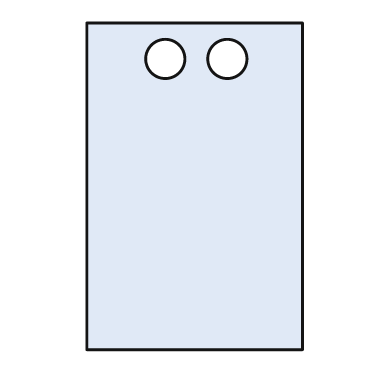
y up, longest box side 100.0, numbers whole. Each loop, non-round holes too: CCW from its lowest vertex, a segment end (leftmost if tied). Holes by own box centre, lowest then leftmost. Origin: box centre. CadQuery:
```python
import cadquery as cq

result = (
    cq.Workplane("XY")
    .moveTo(-33.0, -50.0)
    .lineTo(33.0, -50.0)
    .lineTo(33.0, 50.0)
    .lineTo(-33.0, 50.0)
    .close()
    .moveTo(-9.0, 39.0)
    .circle(6.0)
    .moveTo(10.0, 39.0)
    .circle(6.0)
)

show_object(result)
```